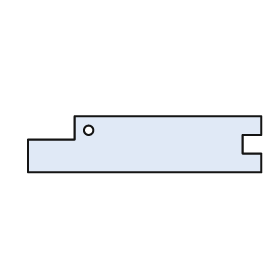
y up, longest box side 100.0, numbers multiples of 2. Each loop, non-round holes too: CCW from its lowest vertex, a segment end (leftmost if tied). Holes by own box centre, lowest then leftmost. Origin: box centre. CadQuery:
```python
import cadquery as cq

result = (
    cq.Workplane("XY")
    .moveTo(-50.0, -12.0)
    .lineTo(50.0, -12.0)
    .lineTo(50.0, -4.0)
    .lineTo(42.0, -4.0)
    .lineTo(42.0, 4.0)
    .lineTo(50.0, 4.0)
    .lineTo(50.0, 12.0)
    .lineTo(-30.0, 12.0)
    .lineTo(-30.0, 2.0)
    .lineTo(-50.0, 2.0)
    .close()
    .moveTo(-24.0, 6.0)
    .circle(2.0)
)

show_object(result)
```